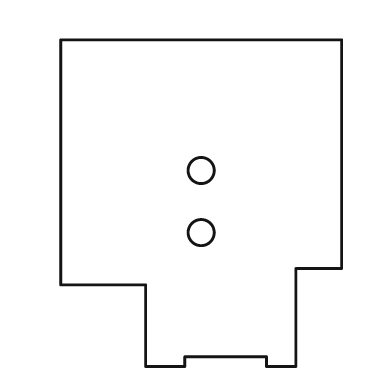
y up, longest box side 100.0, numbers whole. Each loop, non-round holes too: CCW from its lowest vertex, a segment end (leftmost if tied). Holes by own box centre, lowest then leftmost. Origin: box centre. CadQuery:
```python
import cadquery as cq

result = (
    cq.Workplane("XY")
    .moveTo(-17.0, -50.0)
    .lineTo(-5.0, -50.0)
    .lineTo(-5.0, -47.0)
    .lineTo(20.0, -47.0)
    .lineTo(20.0, -50.0)
    .lineTo(29.0, -50.0)
    .lineTo(29.0, -20.0)
    .lineTo(43.0, -20.0)
    .lineTo(43.0, 50.0)
    .lineTo(-43.0, 50.0)
    .lineTo(-43.0, -25.0)
    .lineTo(-17.0, -25.0)
    .close()
    .moveTo(0.0, -9.0)
    .circle(4.0)
    .moveTo(0.0, 10.0)
    .circle(4.0)
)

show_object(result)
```